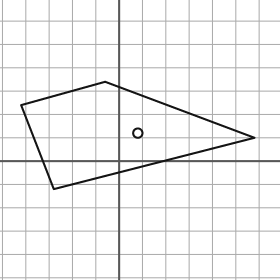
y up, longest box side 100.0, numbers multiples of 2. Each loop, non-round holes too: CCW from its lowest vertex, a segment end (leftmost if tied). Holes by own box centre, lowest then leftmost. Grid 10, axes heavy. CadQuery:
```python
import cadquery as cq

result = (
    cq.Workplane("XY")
    .moveTo(-28.0, -12.0)
    .lineTo(58.0, 10.0)
    .lineTo(-6.0, 34.0)
    .lineTo(-42.0, 24.0)
    .close()
    .moveTo(8.0, 12.0)
    .circle(2.0)
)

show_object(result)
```